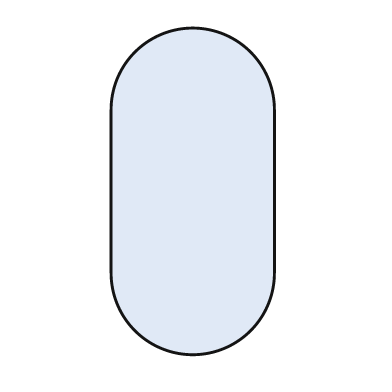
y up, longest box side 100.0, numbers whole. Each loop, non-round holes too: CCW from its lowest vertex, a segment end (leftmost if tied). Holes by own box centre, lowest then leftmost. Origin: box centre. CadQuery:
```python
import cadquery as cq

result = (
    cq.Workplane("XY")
    .moveTo(-25.0, -25.0)
    .threePointArc((0.0, -50.0), (25.0, -25.0))
    .lineTo(25.0, 25.0)
    .threePointArc((0.0, 50.0), (-25.0, 25.0))
    .close()
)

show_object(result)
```